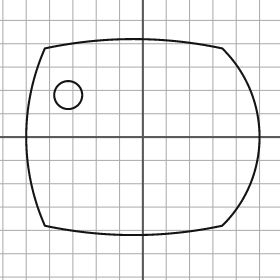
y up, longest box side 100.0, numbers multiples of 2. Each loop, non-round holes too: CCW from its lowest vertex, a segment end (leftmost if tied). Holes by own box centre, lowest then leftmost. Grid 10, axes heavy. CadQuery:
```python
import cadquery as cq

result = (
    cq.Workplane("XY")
    .moveTo(-42.0, -38.0)
    .threePointArc((-4.0, -42.0), (34.0, -38.0))
    .threePointArc((50.0, 0.0), (34.0, 38.0))
    .threePointArc((-4.0, 42.0), (-42.0, 38.0))
    .threePointArc((-50.0, 0.0), (-42.0, -38.0))
    .close()
    .moveTo(-32.0, 18.0)
    .circle(6.0)
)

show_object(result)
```